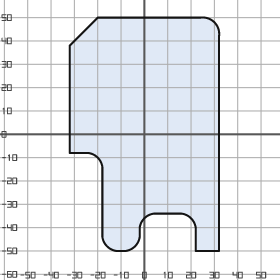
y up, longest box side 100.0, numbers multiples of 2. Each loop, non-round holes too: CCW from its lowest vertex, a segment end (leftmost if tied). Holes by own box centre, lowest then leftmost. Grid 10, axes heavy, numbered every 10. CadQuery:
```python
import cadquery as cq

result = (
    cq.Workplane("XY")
    .moveTo(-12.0, -50.0)
    .lineTo(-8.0, -50.0)
    .threePointArc((-4.0, -48.0), (-2.0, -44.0))
    .lineTo(-2.0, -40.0)
    .threePointArc((0.0, -36.0), (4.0, -34.0))
    .lineTo(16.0, -34.0)
    .threePointArc((20.0, -36.0), (22.0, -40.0))
    .lineTo(22.0, -50.0)
    .lineTo(32.0, -50.0)
    .lineTo(32.0, 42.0)
    .threePointArc((30.0, 48.0), (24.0, 50.0))
    .lineTo(-20.0, 50.0)
    .lineTo(-32.0, 38.0)
    .lineTo(-32.0, -8.0)
    .lineTo(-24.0, -8.0)
    .threePointArc((-20.0, -10.0), (-18.0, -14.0))
    .lineTo(-18.0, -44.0)
    .threePointArc((-16.0, -48.0), (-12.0, -50.0))
    .close()
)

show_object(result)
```